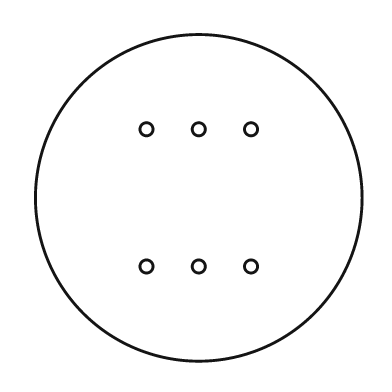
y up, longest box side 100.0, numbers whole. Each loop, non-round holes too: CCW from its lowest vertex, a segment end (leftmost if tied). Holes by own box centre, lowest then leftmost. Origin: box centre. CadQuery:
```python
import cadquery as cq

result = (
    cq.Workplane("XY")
    .moveTo(0.0, 0.0)
    .circle(50.0)
    .moveTo(-16.0, -21.0)
    .circle(2.0)
    .moveTo(0.0, -21.0)
    .circle(2.0)
    .moveTo(16.0, -21.0)
    .circle(2.0)
    .moveTo(-16.0, 21.0)
    .circle(2.0)
    .moveTo(0.0, 21.0)
    .circle(2.0)
    .moveTo(16.0, 21.0)
    .circle(2.0)
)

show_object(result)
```